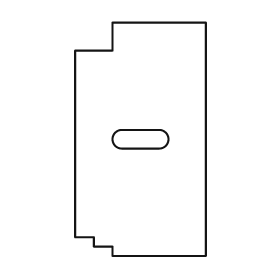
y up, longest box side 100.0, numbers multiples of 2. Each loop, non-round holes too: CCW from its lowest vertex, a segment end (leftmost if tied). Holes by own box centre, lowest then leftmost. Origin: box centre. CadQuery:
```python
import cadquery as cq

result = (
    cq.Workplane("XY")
    .moveTo(-12.0, -50.0)
    .lineTo(28.0, -50.0)
    .lineTo(28.0, 50.0)
    .lineTo(-12.0, 50.0)
    .lineTo(-12.0, 38.0)
    .lineTo(-28.0, 38.0)
    .lineTo(-28.0, -42.0)
    .lineTo(-20.0, -42.0)
    .lineTo(-20.0, -46.0)
    .lineTo(-12.0, -46.0)
    .close()
    .moveTo(-8.0, -4.0)
    .lineTo(8.0, -4.0)
    .threePointArc((12.0, 0.0), (8.0, 4.0))
    .lineTo(-8.0, 4.0)
    .threePointArc((-12.0, 0.0), (-8.0, -4.0))
    .close()
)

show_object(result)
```